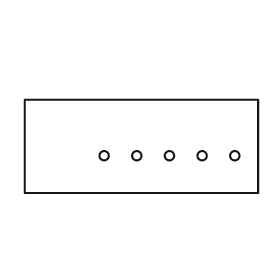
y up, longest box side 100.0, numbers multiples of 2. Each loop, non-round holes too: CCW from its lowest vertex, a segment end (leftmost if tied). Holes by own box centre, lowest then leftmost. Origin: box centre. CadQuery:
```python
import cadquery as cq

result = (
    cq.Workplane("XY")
    .moveTo(-50.0, -20.0)
    .lineTo(50.0, -20.0)
    .lineTo(50.0, 20.0)
    .lineTo(-50.0, 20.0)
    .close()
    .moveTo(-16.0, -4.0)
    .circle(2.0)
    .moveTo(-2.0, -4.0)
    .circle(2.0)
    .moveTo(12.0, -4.0)
    .circle(2.0)
    .moveTo(26.0, -4.0)
    .circle(2.0)
    .moveTo(40.0, -4.0)
    .circle(2.0)
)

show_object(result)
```